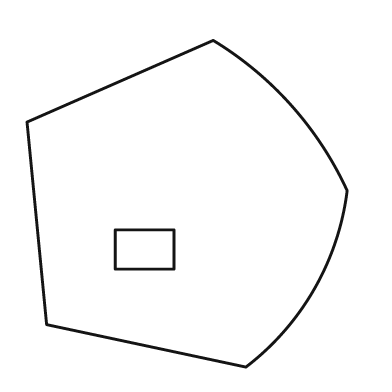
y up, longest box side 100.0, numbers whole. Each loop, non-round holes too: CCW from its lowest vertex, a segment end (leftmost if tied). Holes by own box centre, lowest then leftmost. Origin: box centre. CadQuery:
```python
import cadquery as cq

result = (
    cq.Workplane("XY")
    .moveTo(18.0, -50.0)
    .threePointArc((39.0, -26.0), (49.0, 4.0))
    .threePointArc((32.0, 30.0), (8.0, 50.0))
    .lineTo(-49.0, 25.0)
    .lineTo(-43.0, -37.0)
    .close()
    .moveTo(-22.0, -20.0)
    .lineTo(-4.0, -20.0)
    .lineTo(-4.0, -8.0)
    .lineTo(-22.0, -8.0)
    .close()
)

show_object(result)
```